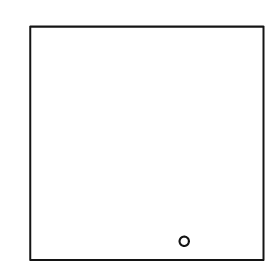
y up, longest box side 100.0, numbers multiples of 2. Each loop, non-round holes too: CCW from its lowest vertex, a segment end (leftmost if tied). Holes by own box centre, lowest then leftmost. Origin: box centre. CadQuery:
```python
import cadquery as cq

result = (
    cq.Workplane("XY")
    .moveTo(-50.0, -50.0)
    .lineTo(50.0, -50.0)
    .lineTo(50.0, 50.0)
    .lineTo(-50.0, 50.0)
    .close()
    .moveTo(16.0, -42.0)
    .circle(2.0)
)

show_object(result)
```